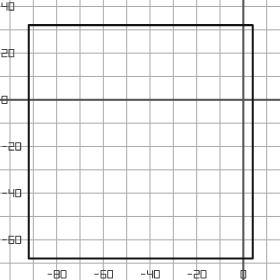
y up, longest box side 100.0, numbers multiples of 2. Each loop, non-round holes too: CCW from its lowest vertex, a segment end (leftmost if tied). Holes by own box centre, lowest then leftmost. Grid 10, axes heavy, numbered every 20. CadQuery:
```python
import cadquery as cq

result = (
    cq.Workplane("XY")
    .moveTo(-92.0, -68.0)
    .lineTo(4.0, -68.0)
    .lineTo(4.0, 32.0)
    .lineTo(-92.0, 32.0)
    .close()
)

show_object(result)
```